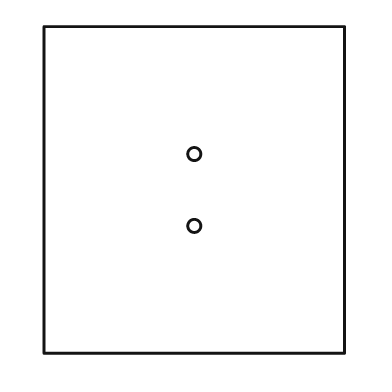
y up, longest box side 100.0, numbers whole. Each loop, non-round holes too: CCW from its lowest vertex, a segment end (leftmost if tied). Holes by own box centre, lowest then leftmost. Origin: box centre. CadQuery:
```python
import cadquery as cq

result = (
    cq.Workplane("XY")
    .moveTo(-46.0, -50.0)
    .lineTo(46.0, -50.0)
    .lineTo(46.0, 50.0)
    .lineTo(-46.0, 50.0)
    .close()
    .moveTo(0.0, -11.0)
    .circle(2.0)
    .moveTo(0.0, 11.0)
    .circle(2.0)
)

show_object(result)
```